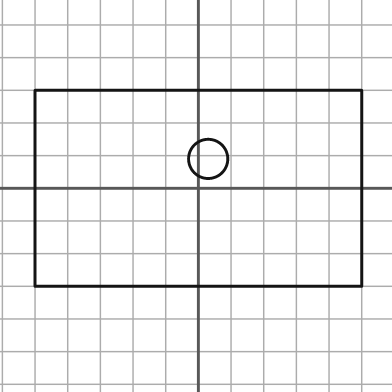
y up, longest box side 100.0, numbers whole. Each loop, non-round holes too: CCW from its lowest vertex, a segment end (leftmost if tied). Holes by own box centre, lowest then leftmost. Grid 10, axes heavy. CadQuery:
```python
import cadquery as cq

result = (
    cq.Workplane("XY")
    .moveTo(-50.0, -30.0)
    .lineTo(50.0, -30.0)
    .lineTo(50.0, 30.0)
    .lineTo(-50.0, 30.0)
    .close()
    .moveTo(3.0, 9.0)
    .circle(6.0)
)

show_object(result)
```